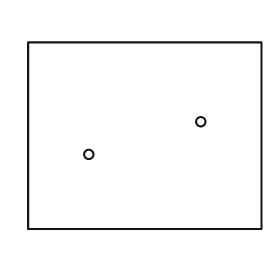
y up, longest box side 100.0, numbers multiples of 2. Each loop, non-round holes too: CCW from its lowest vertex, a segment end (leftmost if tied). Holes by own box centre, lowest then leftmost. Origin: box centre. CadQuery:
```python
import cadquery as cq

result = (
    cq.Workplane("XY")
    .moveTo(-50.0, -40.0)
    .lineTo(50.0, -40.0)
    .lineTo(50.0, 40.0)
    .lineTo(-50.0, 40.0)
    .close()
    .moveTo(-24.0, -8.0)
    .circle(2.0)
    .moveTo(24.0, 6.0)
    .circle(2.0)
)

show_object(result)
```